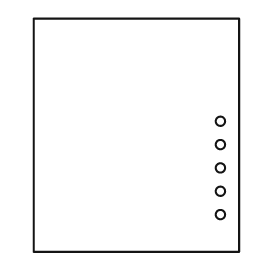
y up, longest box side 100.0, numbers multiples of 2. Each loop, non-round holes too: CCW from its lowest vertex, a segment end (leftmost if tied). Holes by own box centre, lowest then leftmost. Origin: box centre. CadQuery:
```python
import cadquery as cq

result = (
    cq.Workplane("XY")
    .moveTo(-44.0, -50.0)
    .lineTo(44.0, -50.0)
    .lineTo(44.0, 50.0)
    .lineTo(-44.0, 50.0)
    .close()
    .moveTo(36.0, -34.0)
    .circle(2.0)
    .moveTo(36.0, -24.0)
    .circle(2.0)
    .moveTo(36.0, -14.0)
    .circle(2.0)
    .moveTo(36.0, -4.0)
    .circle(2.0)
    .moveTo(36.0, 6.0)
    .circle(2.0)
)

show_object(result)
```